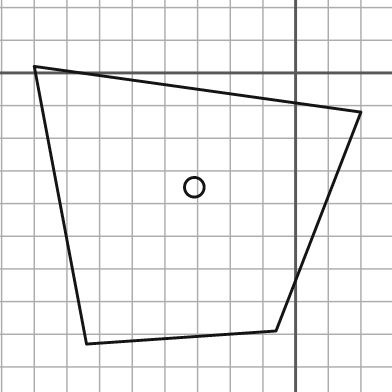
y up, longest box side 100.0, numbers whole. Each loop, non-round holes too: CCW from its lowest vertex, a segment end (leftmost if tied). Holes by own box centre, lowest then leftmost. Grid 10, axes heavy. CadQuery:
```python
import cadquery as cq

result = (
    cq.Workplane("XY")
    .moveTo(-64.0, -83.0)
    .lineTo(-6.0, -79.0)
    .lineTo(20.0, -12.0)
    .lineTo(-80.0, 2.0)
    .close()
    .moveTo(-31.0, -35.0)
    .circle(3.0)
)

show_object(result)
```